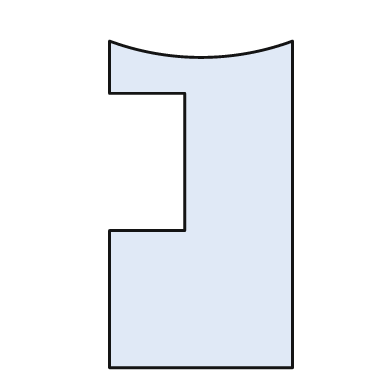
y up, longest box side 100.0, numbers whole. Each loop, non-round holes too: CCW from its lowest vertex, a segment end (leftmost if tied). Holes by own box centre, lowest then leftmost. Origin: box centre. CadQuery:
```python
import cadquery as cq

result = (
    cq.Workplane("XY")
    .moveTo(-28.0, -50.0)
    .lineTo(28.0, -50.0)
    .lineTo(28.0, 50.0)
    .threePointArc((0.0, 45.0), (-28.0, 50.0))
    .lineTo(-28.0, 34.0)
    .lineTo(-5.0, 34.0)
    .lineTo(-5.0, -8.0)
    .lineTo(-28.0, -8.0)
    .close()
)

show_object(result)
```